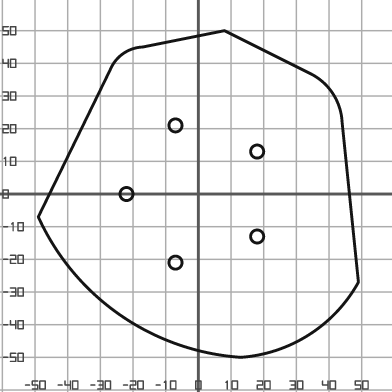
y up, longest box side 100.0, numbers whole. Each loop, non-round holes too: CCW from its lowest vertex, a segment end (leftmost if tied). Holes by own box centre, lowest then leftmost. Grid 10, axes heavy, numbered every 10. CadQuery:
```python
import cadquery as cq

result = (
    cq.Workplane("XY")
    .moveTo(13.0, -50.0)
    .threePointArc((34.0, -43.0), (49.0, -27.0))
    .lineTo(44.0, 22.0)
    .threePointArc((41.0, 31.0), (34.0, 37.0))
    .lineTo(8.0, 50.0)
    .lineTo(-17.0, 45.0)
    .threePointArc((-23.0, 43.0), (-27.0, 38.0))
    .lineTo(-49.0, -7.0)
    .threePointArc((-24.0, -37.0), (13.0, -50.0))
    .close()
    .moveTo(-7.0, -21.0)
    .circle(2.0)
    .moveTo(18.0, -13.0)
    .circle(2.0)
    .moveTo(-22.0, 0.0)
    .circle(2.0)
    .moveTo(18.0, 13.0)
    .circle(2.0)
    .moveTo(-7.0, 21.0)
    .circle(2.0)
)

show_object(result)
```